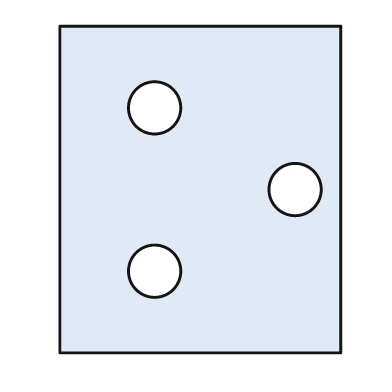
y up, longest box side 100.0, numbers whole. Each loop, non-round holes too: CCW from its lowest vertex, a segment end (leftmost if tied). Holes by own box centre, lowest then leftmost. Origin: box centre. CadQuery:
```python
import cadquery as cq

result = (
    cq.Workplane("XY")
    .moveTo(-43.0, -50.0)
    .lineTo(43.0, -50.0)
    .lineTo(43.0, 50.0)
    .lineTo(-43.0, 50.0)
    .close()
    .moveTo(-14.0, -25.0)
    .circle(8.0)
    .moveTo(29.0, 0.0)
    .circle(8.0)
    .moveTo(-14.0, 25.0)
    .circle(8.0)
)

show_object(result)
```